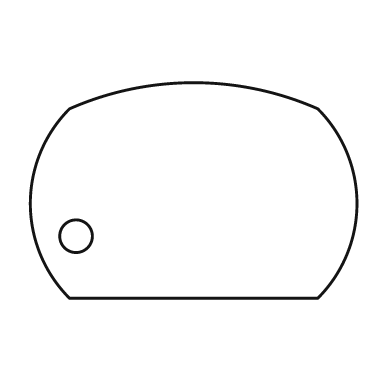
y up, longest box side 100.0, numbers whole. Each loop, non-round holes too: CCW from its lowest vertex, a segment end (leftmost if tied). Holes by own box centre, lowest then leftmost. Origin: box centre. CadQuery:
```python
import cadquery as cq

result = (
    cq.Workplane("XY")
    .moveTo(-38.0, -33.0)
    .lineTo(38.0, -33.0)
    .threePointArc((50.0, -4.0), (38.0, 25.0))
    .threePointArc((0.0, 33.0), (-38.0, 25.0))
    .threePointArc((-50.0, -4.0), (-38.0, -33.0))
    .close()
    .moveTo(-36.0, -14.0)
    .circle(5.0)
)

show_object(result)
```